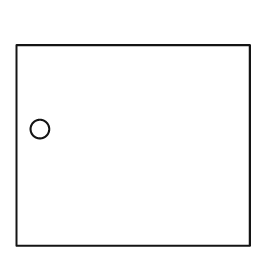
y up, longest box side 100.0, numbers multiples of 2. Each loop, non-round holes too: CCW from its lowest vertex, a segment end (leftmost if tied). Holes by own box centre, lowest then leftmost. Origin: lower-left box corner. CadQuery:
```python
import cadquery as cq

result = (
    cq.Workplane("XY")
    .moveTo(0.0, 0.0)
    .lineTo(100.0, 0.0)
    .lineTo(100.0, 86.0)
    .lineTo(0.0, 86.0)
    .close()
    .moveTo(10.0, 50.0)
    .circle(4.0)
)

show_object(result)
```